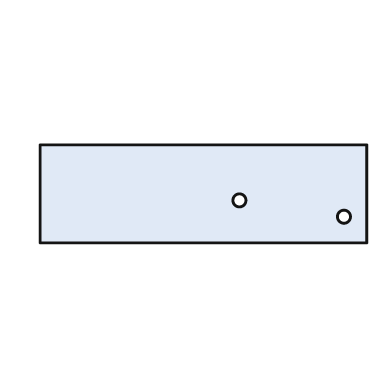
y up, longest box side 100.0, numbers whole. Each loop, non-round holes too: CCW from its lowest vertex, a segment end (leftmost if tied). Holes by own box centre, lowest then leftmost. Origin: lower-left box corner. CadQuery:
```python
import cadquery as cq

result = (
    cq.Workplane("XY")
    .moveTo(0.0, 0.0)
    .lineTo(100.0, 0.0)
    .lineTo(100.0, 30.0)
    .lineTo(0.0, 30.0)
    .close()
    .moveTo(93.0, 8.0)
    .circle(2.0)
    .moveTo(61.0, 13.0)
    .circle(2.0)
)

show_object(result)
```